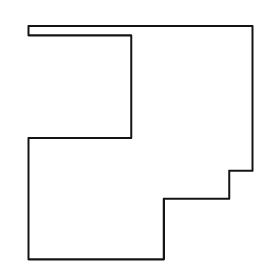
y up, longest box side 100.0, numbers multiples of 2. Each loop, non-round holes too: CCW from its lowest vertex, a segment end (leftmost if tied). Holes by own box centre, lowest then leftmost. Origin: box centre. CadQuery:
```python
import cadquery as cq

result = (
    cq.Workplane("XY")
    .moveTo(-48.0, -50.0)
    .lineTo(10.0, -50.0)
    .lineTo(10.0, -24.0)
    .lineTo(38.0, -24.0)
    .lineTo(38.0, -12.0)
    .lineTo(48.0, -12.0)
    .lineTo(48.0, 50.0)
    .lineTo(-48.0, 50.0)
    .lineTo(-48.0, 46.0)
    .lineTo(-4.0, 46.0)
    .lineTo(-4.0, 2.0)
    .lineTo(-48.0, 2.0)
    .close()
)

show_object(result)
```